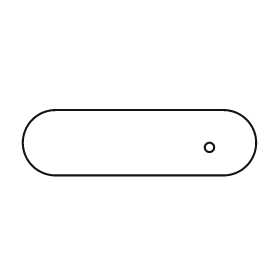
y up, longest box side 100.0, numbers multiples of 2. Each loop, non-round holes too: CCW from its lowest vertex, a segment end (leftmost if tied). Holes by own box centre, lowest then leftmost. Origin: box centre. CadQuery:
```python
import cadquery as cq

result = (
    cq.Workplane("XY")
    .moveTo(-36.0, -14.0)
    .lineTo(36.0, -14.0)
    .threePointArc((50.0, 0.0), (36.0, 14.0))
    .lineTo(-36.0, 14.0)
    .threePointArc((-50.0, 0.0), (-36.0, -14.0))
    .close()
    .moveTo(30.0, -2.0)
    .circle(2.0)
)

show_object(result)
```